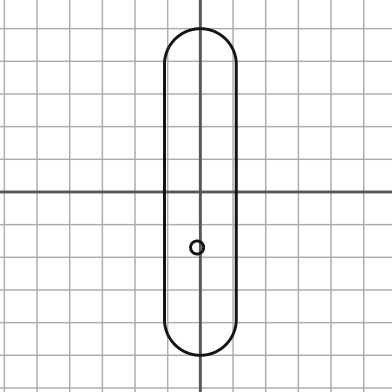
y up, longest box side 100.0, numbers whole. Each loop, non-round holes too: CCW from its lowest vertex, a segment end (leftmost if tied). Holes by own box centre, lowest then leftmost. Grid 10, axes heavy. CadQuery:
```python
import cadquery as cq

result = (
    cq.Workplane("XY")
    .moveTo(-11.0, -39.0)
    .threePointArc((0.0, -50.0), (11.0, -39.0))
    .lineTo(11.0, 39.0)
    .threePointArc((0.0, 50.0), (-11.0, 39.0))
    .close()
    .moveTo(-1.0, -17.0)
    .circle(2.0)
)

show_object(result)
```